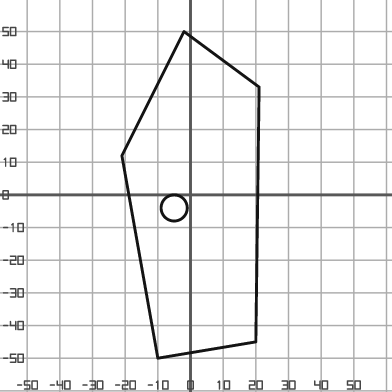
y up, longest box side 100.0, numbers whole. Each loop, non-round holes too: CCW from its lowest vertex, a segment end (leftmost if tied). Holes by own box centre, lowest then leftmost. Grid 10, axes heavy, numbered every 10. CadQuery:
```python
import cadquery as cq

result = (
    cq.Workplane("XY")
    .moveTo(-10.0, -50.0)
    .lineTo(20.0, -45.0)
    .lineTo(21.0, 33.0)
    .lineTo(-2.0, 50.0)
    .lineTo(-21.0, 12.0)
    .close()
    .moveTo(-5.0, -4.0)
    .circle(4.0)
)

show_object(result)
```